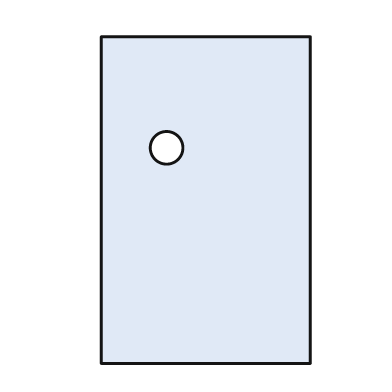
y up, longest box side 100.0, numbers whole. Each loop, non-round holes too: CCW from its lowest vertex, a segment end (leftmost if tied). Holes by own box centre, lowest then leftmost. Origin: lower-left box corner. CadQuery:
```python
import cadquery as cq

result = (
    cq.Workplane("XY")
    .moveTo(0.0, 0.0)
    .lineTo(64.0, 0.0)
    .lineTo(64.0, 100.0)
    .lineTo(0.0, 100.0)
    .close()
    .moveTo(20.0, 66.0)
    .circle(5.0)
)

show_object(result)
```